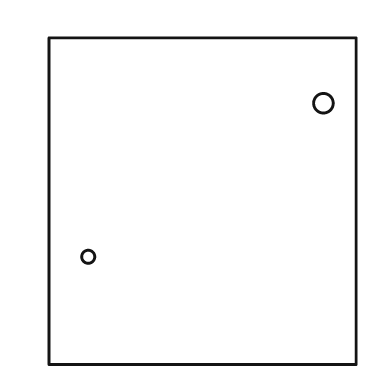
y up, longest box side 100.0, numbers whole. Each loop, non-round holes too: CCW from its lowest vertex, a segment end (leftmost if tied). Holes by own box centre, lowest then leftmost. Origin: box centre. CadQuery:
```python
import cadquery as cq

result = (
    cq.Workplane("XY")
    .moveTo(-47.0, -50.0)
    .lineTo(47.0, -50.0)
    .lineTo(47.0, 50.0)
    .lineTo(-47.0, 50.0)
    .close()
    .moveTo(-35.0, -17.0)
    .circle(2.0)
    .moveTo(37.0, 30.0)
    .circle(3.0)
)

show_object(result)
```